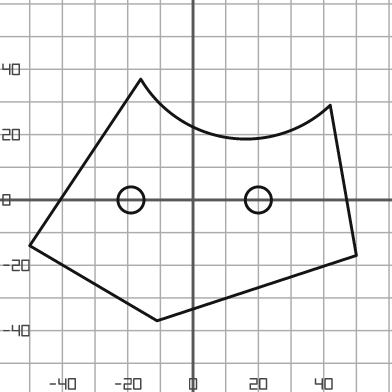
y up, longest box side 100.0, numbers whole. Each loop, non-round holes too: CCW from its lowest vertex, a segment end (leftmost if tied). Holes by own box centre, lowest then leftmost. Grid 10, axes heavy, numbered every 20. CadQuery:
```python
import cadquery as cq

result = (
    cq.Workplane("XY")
    .moveTo(-11.0, -37.0)
    .lineTo(50.0, -17.0)
    .lineTo(42.0, 29.0)
    .threePointArc((11.0, 19.0), (-16.0, 37.0))
    .lineTo(-50.0, -14.0)
    .close()
    .moveTo(-19.0, 0.0)
    .circle(4.0)
    .moveTo(20.0, 0.0)
    .circle(4.0)
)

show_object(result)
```